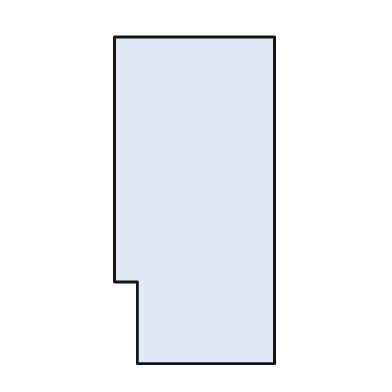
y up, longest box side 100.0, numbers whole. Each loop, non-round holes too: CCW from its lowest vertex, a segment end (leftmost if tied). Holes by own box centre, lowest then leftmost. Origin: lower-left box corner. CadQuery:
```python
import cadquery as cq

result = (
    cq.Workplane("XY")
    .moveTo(7.0, 0.0)
    .lineTo(49.0, 0.0)
    .lineTo(49.0, 100.0)
    .lineTo(0.0, 100.0)
    .lineTo(0.0, 25.0)
    .lineTo(7.0, 25.0)
    .close()
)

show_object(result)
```